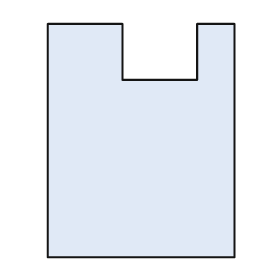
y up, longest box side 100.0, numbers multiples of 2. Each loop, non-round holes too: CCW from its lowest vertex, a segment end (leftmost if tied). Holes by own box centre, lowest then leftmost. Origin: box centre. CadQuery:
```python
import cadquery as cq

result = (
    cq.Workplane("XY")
    .moveTo(-40.0, -50.0)
    .lineTo(40.0, -50.0)
    .lineTo(40.0, 50.0)
    .lineTo(24.0, 50.0)
    .lineTo(24.0, 26.0)
    .lineTo(-8.0, 26.0)
    .lineTo(-8.0, 50.0)
    .lineTo(-40.0, 50.0)
    .close()
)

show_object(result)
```